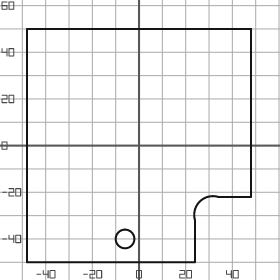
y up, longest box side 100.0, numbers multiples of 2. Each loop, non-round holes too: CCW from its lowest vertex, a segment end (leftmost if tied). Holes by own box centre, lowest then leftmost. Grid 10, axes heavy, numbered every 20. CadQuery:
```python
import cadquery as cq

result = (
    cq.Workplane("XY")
    .moveTo(-48.0, -50.0)
    .lineTo(24.0, -50.0)
    .lineTo(24.0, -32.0)
    .threePointArc((26.0, -24.0), (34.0, -22.0))
    .lineTo(48.0, -22.0)
    .lineTo(48.0, 50.0)
    .lineTo(-48.0, 50.0)
    .close()
    .moveTo(-6.0, -40.0)
    .circle(4.0)
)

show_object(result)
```